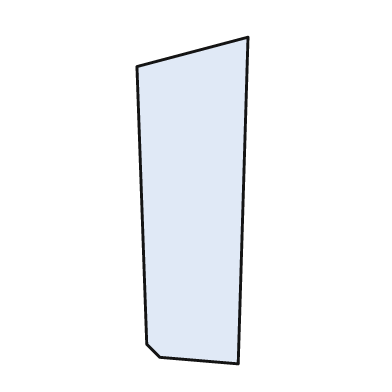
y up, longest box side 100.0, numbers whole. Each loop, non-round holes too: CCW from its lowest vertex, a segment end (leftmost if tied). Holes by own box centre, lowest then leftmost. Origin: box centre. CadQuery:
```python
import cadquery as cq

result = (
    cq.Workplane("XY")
    .moveTo(14.0, -50.0)
    .lineTo(17.0, 50.0)
    .lineTo(-17.0, 41.0)
    .lineTo(-14.0, -44.0)
    .lineTo(-10.0, -48.0)
    .close()
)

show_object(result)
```